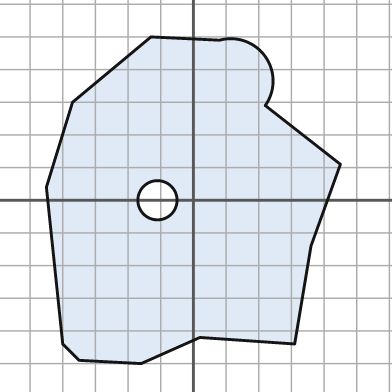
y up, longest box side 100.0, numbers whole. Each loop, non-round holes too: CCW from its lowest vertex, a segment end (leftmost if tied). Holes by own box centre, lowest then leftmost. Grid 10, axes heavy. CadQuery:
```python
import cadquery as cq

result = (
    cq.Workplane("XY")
    .moveTo(-16.0, -50.0)
    .lineTo(2.0, -42.0)
    .lineTo(31.0, -44.0)
    .lineTo(36.0, -14.0)
    .lineTo(45.0, 11.0)
    .lineTo(22.0, 29.0)
    .threePointArc((22.0, 44.0), (8.0, 49.0))
    .lineTo(-13.0, 50.0)
    .lineTo(-37.0, 30.0)
    .lineTo(-45.0, 4.0)
    .lineTo(-40.0, -44.0)
    .lineTo(-35.0, -49.0)
    .close()
    .moveTo(-11.0, 0.0)
    .circle(6.0)
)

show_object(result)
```